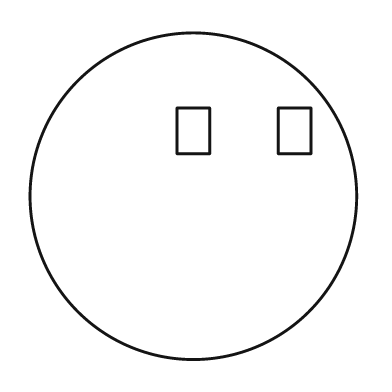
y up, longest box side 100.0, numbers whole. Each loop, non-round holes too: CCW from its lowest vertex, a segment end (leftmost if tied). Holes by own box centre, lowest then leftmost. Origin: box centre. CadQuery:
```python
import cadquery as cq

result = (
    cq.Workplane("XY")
    .moveTo(0.0, 0.0)
    .circle(50.0)
    .moveTo(-5.0, 13.0)
    .lineTo(5.0, 13.0)
    .lineTo(5.0, 27.0)
    .lineTo(-5.0, 27.0)
    .close()
    .moveTo(26.0, 13.0)
    .lineTo(36.0, 13.0)
    .lineTo(36.0, 27.0)
    .lineTo(26.0, 27.0)
    .close()
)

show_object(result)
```